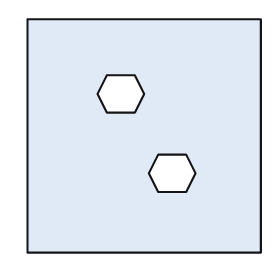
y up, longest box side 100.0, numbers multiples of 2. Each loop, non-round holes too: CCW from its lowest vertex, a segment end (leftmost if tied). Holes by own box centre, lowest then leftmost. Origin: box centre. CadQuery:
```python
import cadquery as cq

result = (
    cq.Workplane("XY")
    .moveTo(-50.0, -50.0)
    .lineTo(50.0, -50.0)
    .lineTo(50.0, 50.0)
    .lineTo(-50.0, 50.0)
    .close()
    .moveTo(6.0, -24.0)
    .lineTo(18.0, -24.0)
    .lineTo(22.0, -16.0)
    .lineTo(18.0, -8.0)
    .lineTo(6.0, -8.0)
    .lineTo(2.0, -16.0)
    .close()
    .moveTo(-16.0, 10.0)
    .lineTo(-4.0, 10.0)
    .lineTo(0.0, 18.0)
    .lineTo(-4.0, 26.0)
    .lineTo(-16.0, 26.0)
    .lineTo(-20.0, 18.0)
    .close()
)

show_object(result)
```